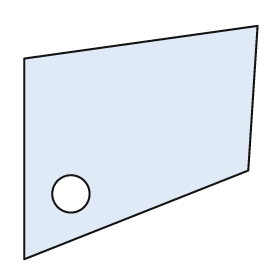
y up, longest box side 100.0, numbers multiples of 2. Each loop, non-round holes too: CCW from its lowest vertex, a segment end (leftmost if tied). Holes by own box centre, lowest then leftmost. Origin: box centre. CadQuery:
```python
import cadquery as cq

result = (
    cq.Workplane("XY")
    .moveTo(-50.0, -50.0)
    .lineTo(46.0, -12.0)
    .lineTo(50.0, 50.0)
    .lineTo(-50.0, 36.0)
    .close()
    .moveTo(-30.0, -22.0)
    .circle(8.0)
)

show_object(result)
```